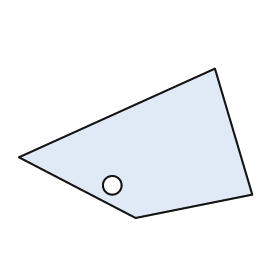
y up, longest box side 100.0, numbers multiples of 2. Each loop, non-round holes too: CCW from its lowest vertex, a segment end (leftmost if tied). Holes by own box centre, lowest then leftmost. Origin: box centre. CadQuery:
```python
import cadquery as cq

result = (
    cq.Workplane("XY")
    .moveTo(0.0, -32.0)
    .lineTo(50.0, -22.0)
    .lineTo(34.0, 32.0)
    .lineTo(-50.0, -6.0)
    .close()
    .moveTo(-10.0, -18.0)
    .circle(4.0)
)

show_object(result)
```